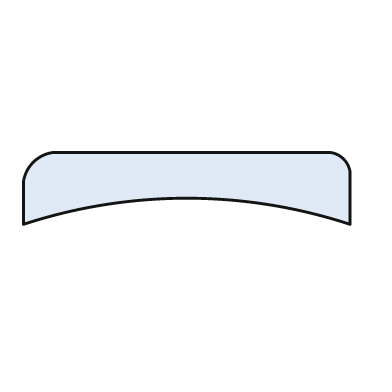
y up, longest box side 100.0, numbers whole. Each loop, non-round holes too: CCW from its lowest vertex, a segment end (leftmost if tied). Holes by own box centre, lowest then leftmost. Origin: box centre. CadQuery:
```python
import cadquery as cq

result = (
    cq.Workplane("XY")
    .moveTo(-50.0, -11.0)
    .threePointArc((0.0, -3.0), (50.0, -11.0))
    .lineTo(50.0, 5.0)
    .threePointArc((48.0, 9.0), (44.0, 11.0))
    .lineTo(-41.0, 11.0)
    .threePointArc((-47.0, 8.0), (-50.0, 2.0))
    .close()
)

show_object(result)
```